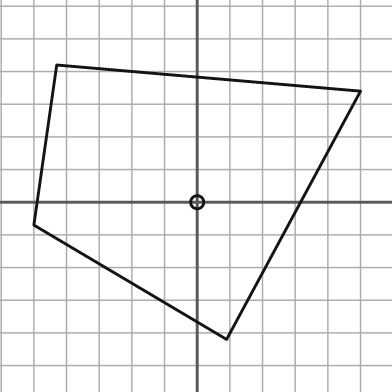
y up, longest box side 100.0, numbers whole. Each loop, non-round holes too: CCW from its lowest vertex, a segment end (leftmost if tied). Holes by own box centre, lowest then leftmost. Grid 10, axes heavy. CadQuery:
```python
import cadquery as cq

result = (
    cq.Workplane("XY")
    .moveTo(9.0, -42.0)
    .lineTo(50.0, 34.0)
    .lineTo(-43.0, 42.0)
    .lineTo(-50.0, -7.0)
    .close()
    .moveTo(0.0, 0.0)
    .circle(2.0)
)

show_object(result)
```